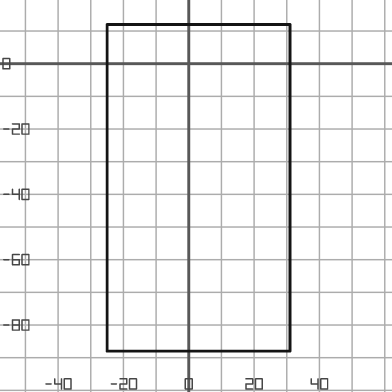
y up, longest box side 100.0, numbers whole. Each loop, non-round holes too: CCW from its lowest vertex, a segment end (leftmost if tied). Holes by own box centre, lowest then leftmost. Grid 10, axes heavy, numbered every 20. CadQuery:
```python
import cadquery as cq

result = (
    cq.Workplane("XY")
    .moveTo(-25.0, -88.0)
    .lineTo(31.0, -88.0)
    .lineTo(31.0, 12.0)
    .lineTo(-25.0, 12.0)
    .close()
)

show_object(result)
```